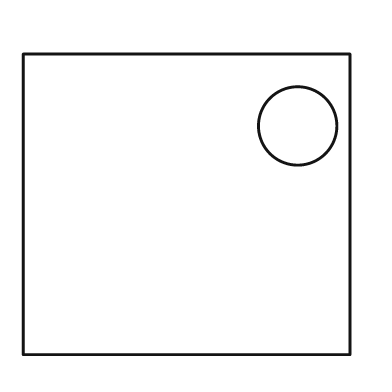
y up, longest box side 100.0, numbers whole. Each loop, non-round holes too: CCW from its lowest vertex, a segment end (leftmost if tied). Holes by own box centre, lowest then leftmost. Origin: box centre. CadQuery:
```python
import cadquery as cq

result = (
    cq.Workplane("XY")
    .moveTo(-50.0, -46.0)
    .lineTo(50.0, -46.0)
    .lineTo(50.0, 46.0)
    .lineTo(-50.0, 46.0)
    .close()
    .moveTo(34.0, 24.0)
    .circle(12.0)
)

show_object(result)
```